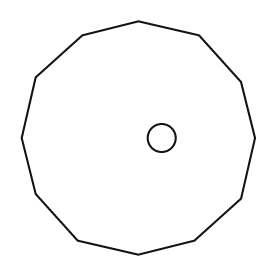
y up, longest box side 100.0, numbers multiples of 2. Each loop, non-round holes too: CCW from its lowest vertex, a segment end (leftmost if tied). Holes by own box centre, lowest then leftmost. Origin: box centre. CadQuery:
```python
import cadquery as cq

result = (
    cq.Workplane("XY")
    .moveTo(0.0, -50.0)
    .lineTo(24.0, -44.0)
    .lineTo(44.0, -26.0)
    .lineTo(50.0, 0.0)
    .lineTo(44.0, 24.0)
    .lineTo(26.0, 44.0)
    .lineTo(0.0, 50.0)
    .lineTo(-24.0, 44.0)
    .lineTo(-44.0, 26.0)
    .lineTo(-50.0, 0.0)
    .lineTo(-44.0, -24.0)
    .lineTo(-26.0, -44.0)
    .close()
    .moveTo(10.0, 0.0)
    .circle(6.0)
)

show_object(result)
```